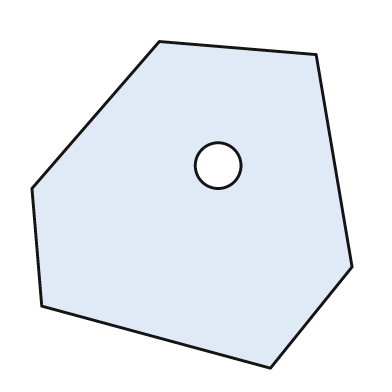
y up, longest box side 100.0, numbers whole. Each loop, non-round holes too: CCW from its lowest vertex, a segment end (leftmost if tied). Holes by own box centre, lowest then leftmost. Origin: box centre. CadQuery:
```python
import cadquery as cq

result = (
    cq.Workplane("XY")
    .moveTo(24.0, -50.0)
    .lineTo(49.0, -19.0)
    .lineTo(38.0, 46.0)
    .lineTo(-10.0, 50.0)
    .lineTo(-49.0, 5.0)
    .lineTo(-46.0, -31.0)
    .close()
    .moveTo(8.0, 12.0)
    .circle(7.0)
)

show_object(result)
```